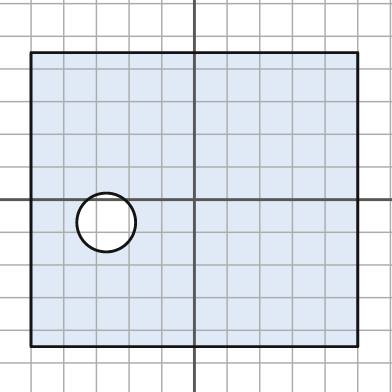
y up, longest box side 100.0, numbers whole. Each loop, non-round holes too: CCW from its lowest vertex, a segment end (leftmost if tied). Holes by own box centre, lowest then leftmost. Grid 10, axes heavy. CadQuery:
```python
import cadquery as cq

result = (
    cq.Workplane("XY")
    .moveTo(-50.0, -45.0)
    .lineTo(50.0, -45.0)
    .lineTo(50.0, 45.0)
    .lineTo(-50.0, 45.0)
    .close()
    .moveTo(-27.0, -7.0)
    .circle(9.0)
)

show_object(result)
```